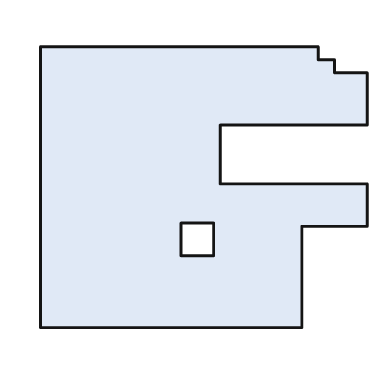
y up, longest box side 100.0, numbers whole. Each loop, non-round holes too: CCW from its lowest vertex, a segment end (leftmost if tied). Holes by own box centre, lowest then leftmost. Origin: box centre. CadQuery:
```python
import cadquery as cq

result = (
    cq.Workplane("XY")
    .moveTo(-50.0, -43.0)
    .lineTo(30.0, -43.0)
    .lineTo(30.0, -12.0)
    .lineTo(50.0, -12.0)
    .lineTo(50.0, 1.0)
    .lineTo(5.0, 1.0)
    .lineTo(5.0, 19.0)
    .lineTo(50.0, 19.0)
    .lineTo(50.0, 35.0)
    .lineTo(40.0, 35.0)
    .lineTo(40.0, 39.0)
    .lineTo(35.0, 39.0)
    .lineTo(35.0, 43.0)
    .lineTo(-50.0, 43.0)
    .close()
    .moveTo(-7.0, -21.0)
    .lineTo(3.0, -21.0)
    .lineTo(3.0, -11.0)
    .lineTo(-7.0, -11.0)
    .close()
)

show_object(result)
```